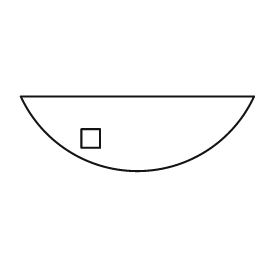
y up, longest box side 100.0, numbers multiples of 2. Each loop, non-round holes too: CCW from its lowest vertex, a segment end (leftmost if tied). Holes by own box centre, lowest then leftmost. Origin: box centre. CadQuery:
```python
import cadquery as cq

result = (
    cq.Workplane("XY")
    .moveTo(-50.0, 16.0)
    .threePointArc((0.0, -16.0), (50.0, 16.0))
    .close()
    .moveTo(-24.0, -6.0)
    .lineTo(-16.0, -6.0)
    .lineTo(-16.0, 2.0)
    .lineTo(-24.0, 2.0)
    .close()
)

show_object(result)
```